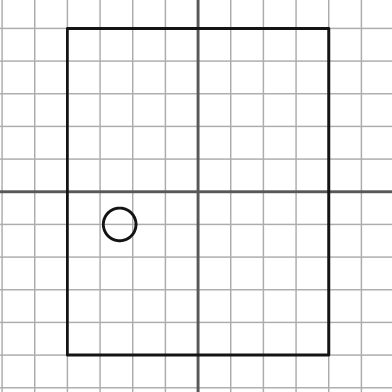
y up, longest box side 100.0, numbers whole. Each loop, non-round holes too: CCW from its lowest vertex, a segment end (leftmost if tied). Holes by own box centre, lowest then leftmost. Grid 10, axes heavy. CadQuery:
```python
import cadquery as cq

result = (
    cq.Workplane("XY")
    .moveTo(-40.0, -50.0)
    .lineTo(40.0, -50.0)
    .lineTo(40.0, 50.0)
    .lineTo(-40.0, 50.0)
    .close()
    .moveTo(-24.0, -10.0)
    .circle(5.0)
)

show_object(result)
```